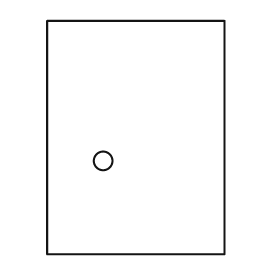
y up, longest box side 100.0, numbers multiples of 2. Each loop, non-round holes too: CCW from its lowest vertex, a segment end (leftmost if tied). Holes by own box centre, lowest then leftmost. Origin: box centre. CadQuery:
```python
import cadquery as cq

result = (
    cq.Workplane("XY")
    .moveTo(-38.0, -50.0)
    .lineTo(38.0, -50.0)
    .lineTo(38.0, 50.0)
    .lineTo(-38.0, 50.0)
    .close()
    .moveTo(-14.0, -10.0)
    .circle(4.0)
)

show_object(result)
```